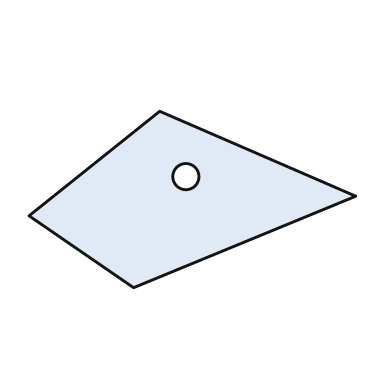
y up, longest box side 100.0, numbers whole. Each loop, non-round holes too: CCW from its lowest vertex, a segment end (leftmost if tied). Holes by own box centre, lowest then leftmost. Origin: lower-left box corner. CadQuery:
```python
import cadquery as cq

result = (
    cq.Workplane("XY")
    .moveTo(32.0, 0.0)
    .lineTo(100.0, 28.0)
    .lineTo(40.0, 54.0)
    .lineTo(0.0, 22.0)
    .close()
    .moveTo(48.0, 34.0)
    .circle(4.0)
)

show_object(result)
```